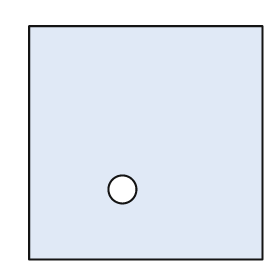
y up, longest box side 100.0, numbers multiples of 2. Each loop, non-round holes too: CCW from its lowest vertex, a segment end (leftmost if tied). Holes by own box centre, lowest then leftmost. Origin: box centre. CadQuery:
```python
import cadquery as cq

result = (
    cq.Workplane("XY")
    .moveTo(-50.0, -50.0)
    .lineTo(50.0, -50.0)
    .lineTo(50.0, 50.0)
    .lineTo(-50.0, 50.0)
    .close()
    .moveTo(-10.0, -20.0)
    .circle(6.0)
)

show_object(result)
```